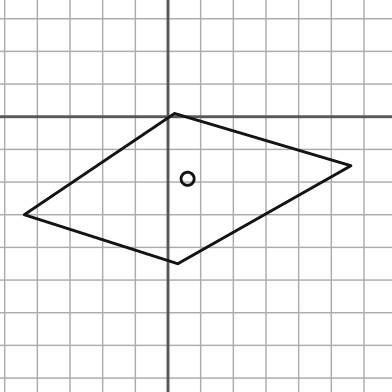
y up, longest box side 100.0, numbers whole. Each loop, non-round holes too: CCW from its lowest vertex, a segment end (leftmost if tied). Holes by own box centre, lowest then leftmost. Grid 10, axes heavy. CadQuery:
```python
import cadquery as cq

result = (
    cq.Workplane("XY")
    .moveTo(3.0, -45.0)
    .lineTo(56.0, -15.0)
    .lineTo(2.0, 1.0)
    .lineTo(-44.0, -30.0)
    .close()
    .moveTo(6.0, -19.0)
    .circle(2.0)
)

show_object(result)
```